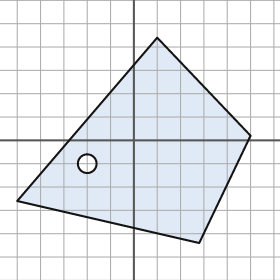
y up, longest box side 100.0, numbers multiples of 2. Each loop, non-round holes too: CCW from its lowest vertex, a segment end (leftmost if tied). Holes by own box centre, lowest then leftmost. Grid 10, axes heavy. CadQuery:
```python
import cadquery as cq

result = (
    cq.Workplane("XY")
    .moveTo(28.0, -44.0)
    .lineTo(50.0, 2.0)
    .lineTo(10.0, 44.0)
    .lineTo(-50.0, -26.0)
    .close()
    .moveTo(-20.0, -10.0)
    .circle(4.0)
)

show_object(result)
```